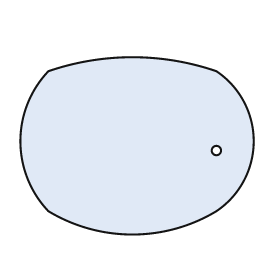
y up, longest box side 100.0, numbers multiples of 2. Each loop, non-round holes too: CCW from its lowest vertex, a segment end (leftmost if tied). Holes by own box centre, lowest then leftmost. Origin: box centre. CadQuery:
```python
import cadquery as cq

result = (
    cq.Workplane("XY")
    .moveTo(-38.0, -28.0)
    .threePointArc((-2.0, -38.0), (34.0, -28.0))
    .threePointArc((50.0, 2.0), (34.0, 32.0))
    .threePointArc((-2.0, 38.0), (-38.0, 32.0))
    .threePointArc((-50.0, 2.0), (-38.0, -28.0))
    .close()
    .moveTo(34.0, -2.0)
    .circle(2.0)
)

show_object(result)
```